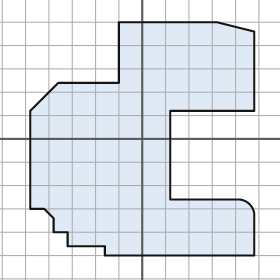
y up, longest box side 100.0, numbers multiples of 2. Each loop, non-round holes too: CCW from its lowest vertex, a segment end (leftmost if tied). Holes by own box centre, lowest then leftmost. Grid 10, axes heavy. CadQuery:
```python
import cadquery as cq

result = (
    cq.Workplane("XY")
    .moveTo(-16.0, -50.0)
    .lineTo(48.0, -50.0)
    .lineTo(48.0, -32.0)
    .threePointArc((46.0, -28.0), (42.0, -26.0))
    .lineTo(12.0, -26.0)
    .lineTo(12.0, 12.0)
    .lineTo(48.0, 12.0)
    .lineTo(48.0, 46.0)
    .lineTo(32.0, 50.0)
    .lineTo(-10.0, 50.0)
    .lineTo(-10.0, 24.0)
    .lineTo(-36.0, 24.0)
    .lineTo(-48.0, 12.0)
    .lineTo(-48.0, -30.0)
    .lineTo(-42.0, -30.0)
    .lineTo(-38.0, -34.0)
    .lineTo(-38.0, -40.0)
    .lineTo(-32.0, -40.0)
    .lineTo(-32.0, -46.0)
    .lineTo(-16.0, -46.0)
    .close()
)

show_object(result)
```